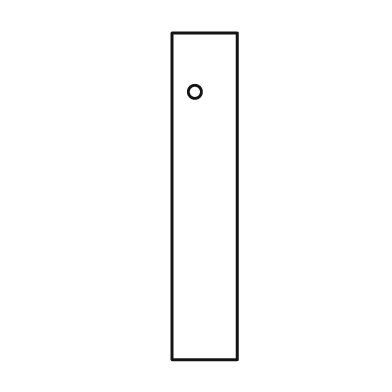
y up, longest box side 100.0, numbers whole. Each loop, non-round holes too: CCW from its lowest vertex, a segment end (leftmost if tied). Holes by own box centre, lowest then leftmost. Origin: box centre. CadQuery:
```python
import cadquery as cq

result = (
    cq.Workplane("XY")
    .moveTo(-10.0, -50.0)
    .lineTo(10.0, -50.0)
    .lineTo(10.0, 50.0)
    .lineTo(-10.0, 50.0)
    .close()
    .moveTo(-3.0, 32.0)
    .circle(2.0)
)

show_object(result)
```